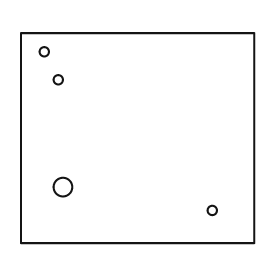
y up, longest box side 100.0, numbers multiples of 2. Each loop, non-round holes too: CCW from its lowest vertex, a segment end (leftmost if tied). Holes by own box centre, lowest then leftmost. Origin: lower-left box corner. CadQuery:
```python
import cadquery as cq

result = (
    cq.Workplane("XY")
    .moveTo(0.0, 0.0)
    .lineTo(100.0, 0.0)
    .lineTo(100.0, 90.0)
    .lineTo(0.0, 90.0)
    .close()
    .moveTo(82.0, 14.0)
    .circle(2.0)
    .moveTo(18.0, 24.0)
    .circle(4.0)
    .moveTo(16.0, 70.0)
    .circle(2.0)
    .moveTo(10.0, 82.0)
    .circle(2.0)
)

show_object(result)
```